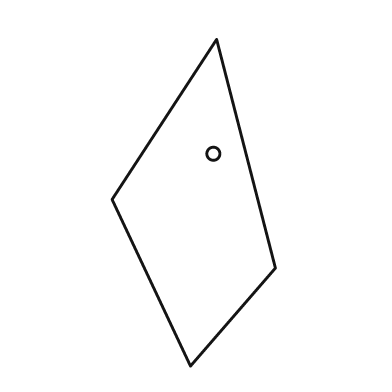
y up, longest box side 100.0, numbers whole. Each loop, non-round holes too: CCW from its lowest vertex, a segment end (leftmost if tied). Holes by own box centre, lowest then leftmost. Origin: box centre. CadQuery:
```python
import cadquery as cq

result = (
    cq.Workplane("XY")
    .moveTo(-1.0, -50.0)
    .lineTo(25.0, -20.0)
    .lineTo(7.0, 50.0)
    .lineTo(-25.0, 1.0)
    .close()
    .moveTo(6.0, 15.0)
    .circle(2.0)
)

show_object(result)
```